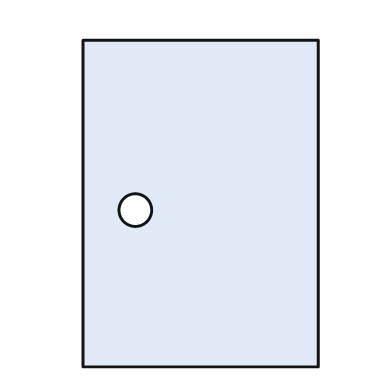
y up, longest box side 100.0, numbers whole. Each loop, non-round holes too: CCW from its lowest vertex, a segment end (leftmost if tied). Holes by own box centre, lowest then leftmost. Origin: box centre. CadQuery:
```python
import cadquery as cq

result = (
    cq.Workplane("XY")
    .moveTo(-36.0, -50.0)
    .lineTo(36.0, -50.0)
    .lineTo(36.0, 50.0)
    .lineTo(-36.0, 50.0)
    .close()
    .moveTo(-20.0, -2.0)
    .circle(5.0)
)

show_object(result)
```